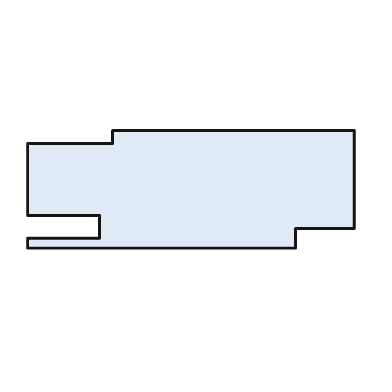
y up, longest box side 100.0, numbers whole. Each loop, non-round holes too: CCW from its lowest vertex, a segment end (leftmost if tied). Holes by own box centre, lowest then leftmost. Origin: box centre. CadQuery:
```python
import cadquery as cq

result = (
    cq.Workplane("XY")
    .moveTo(-50.0, -18.0)
    .lineTo(32.0, -18.0)
    .lineTo(32.0, -12.0)
    .lineTo(50.0, -12.0)
    .lineTo(50.0, 18.0)
    .lineTo(-24.0, 18.0)
    .lineTo(-24.0, 14.0)
    .lineTo(-50.0, 14.0)
    .lineTo(-50.0, -8.0)
    .lineTo(-28.0, -8.0)
    .lineTo(-28.0, -15.0)
    .lineTo(-50.0, -15.0)
    .close()
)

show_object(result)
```